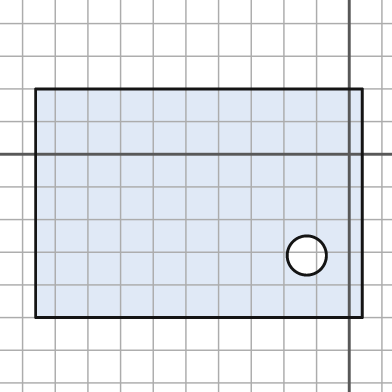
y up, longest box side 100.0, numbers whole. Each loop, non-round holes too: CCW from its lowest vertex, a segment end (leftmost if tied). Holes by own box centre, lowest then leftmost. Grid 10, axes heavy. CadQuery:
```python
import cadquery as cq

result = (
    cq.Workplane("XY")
    .moveTo(-96.0, -50.0)
    .lineTo(4.0, -50.0)
    .lineTo(4.0, 20.0)
    .lineTo(-96.0, 20.0)
    .close()
    .moveTo(-13.0, -31.0)
    .circle(6.0)
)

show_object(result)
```